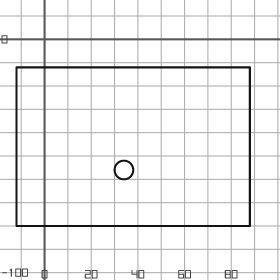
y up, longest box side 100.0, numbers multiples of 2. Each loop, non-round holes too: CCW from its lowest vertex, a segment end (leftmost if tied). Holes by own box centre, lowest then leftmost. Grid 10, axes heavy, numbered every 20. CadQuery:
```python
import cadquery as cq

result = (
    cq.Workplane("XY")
    .moveTo(-12.0, -80.0)
    .lineTo(88.0, -80.0)
    .lineTo(88.0, -12.0)
    .lineTo(-12.0, -12.0)
    .close()
    .moveTo(34.0, -56.0)
    .circle(4.0)
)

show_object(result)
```